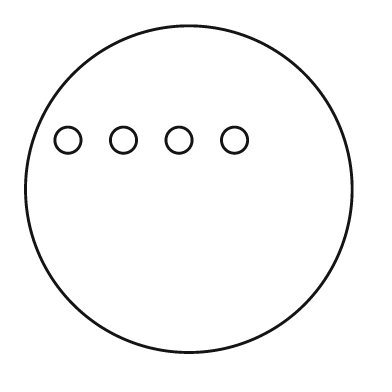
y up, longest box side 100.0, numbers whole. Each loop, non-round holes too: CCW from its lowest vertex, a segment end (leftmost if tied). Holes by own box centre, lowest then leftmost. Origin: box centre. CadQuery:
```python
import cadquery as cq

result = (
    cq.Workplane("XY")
    .moveTo(0.0, 0.0)
    .circle(50.0)
    .moveTo(-37.0, 15.0)
    .circle(4.0)
    .moveTo(-20.0, 15.0)
    .circle(4.0)
    .moveTo(-3.0, 15.0)
    .circle(4.0)
    .moveTo(14.0, 15.0)
    .circle(4.0)
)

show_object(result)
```